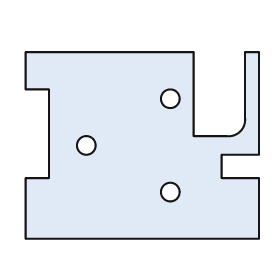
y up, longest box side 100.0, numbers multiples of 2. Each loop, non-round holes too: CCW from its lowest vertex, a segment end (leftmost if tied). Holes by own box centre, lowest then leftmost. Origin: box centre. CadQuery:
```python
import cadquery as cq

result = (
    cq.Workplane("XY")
    .moveTo(-50.0, -40.0)
    .lineTo(50.0, -40.0)
    .lineTo(50.0, -14.0)
    .lineTo(34.0, -14.0)
    .lineTo(34.0, -4.0)
    .lineTo(50.0, -4.0)
    .lineTo(50.0, 40.0)
    .lineTo(44.0, 40.0)
    .lineTo(44.0, 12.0)
    .threePointArc((42.0, 6.0), (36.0, 4.0))
    .lineTo(22.0, 4.0)
    .lineTo(22.0, 40.0)
    .lineTo(-50.0, 40.0)
    .lineTo(-50.0, 24.0)
    .lineTo(-40.0, 24.0)
    .lineTo(-40.0, -14.0)
    .lineTo(-50.0, -14.0)
    .close()
    .moveTo(12.0, -20.0)
    .circle(4.0)
    .moveTo(-24.0, 0.0)
    .circle(4.0)
    .moveTo(12.0, 20.0)
    .circle(4.0)
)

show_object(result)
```